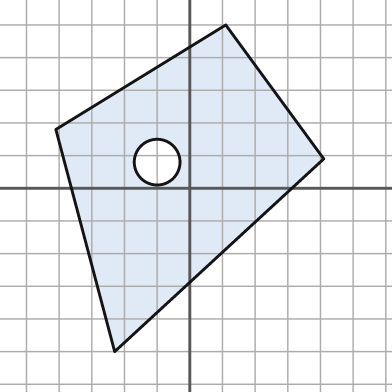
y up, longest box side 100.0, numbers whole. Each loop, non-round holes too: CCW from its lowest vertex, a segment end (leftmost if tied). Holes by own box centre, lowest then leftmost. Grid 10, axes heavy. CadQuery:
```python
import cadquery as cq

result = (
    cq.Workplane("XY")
    .moveTo(-23.0, -50.0)
    .lineTo(41.0, 9.0)
    .lineTo(11.0, 50.0)
    .lineTo(-41.0, 18.0)
    .close()
    .moveTo(-10.0, 8.0)
    .circle(7.0)
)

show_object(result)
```